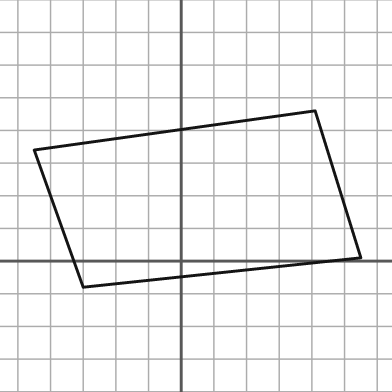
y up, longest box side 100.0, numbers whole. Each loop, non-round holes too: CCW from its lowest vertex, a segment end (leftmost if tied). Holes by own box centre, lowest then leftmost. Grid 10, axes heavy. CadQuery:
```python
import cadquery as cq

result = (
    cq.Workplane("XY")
    .moveTo(-30.0, -8.0)
    .lineTo(55.0, 1.0)
    .lineTo(41.0, 46.0)
    .lineTo(-45.0, 34.0)
    .close()
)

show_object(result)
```